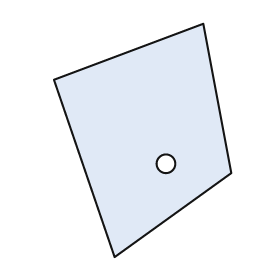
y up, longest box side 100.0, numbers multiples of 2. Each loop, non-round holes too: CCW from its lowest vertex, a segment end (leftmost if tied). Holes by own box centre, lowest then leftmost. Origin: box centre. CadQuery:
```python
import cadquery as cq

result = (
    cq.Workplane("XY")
    .moveTo(-12.0, -50.0)
    .lineTo(38.0, -14.0)
    .lineTo(26.0, 50.0)
    .lineTo(-38.0, 26.0)
    .close()
    .moveTo(10.0, -10.0)
    .circle(4.0)
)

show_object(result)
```